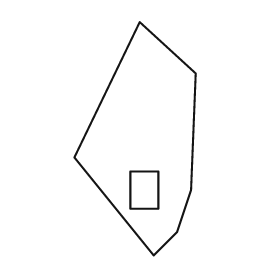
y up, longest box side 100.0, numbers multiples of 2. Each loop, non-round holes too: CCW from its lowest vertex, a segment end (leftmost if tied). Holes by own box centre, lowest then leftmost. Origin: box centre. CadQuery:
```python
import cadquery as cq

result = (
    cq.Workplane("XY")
    .moveTo(8.0, -50.0)
    .lineTo(18.0, -40.0)
    .lineTo(24.0, -22.0)
    .lineTo(26.0, 28.0)
    .lineTo(2.0, 50.0)
    .lineTo(-26.0, -8.0)
    .close()
    .moveTo(-2.0, -30.0)
    .lineTo(10.0, -30.0)
    .lineTo(10.0, -14.0)
    .lineTo(-2.0, -14.0)
    .close()
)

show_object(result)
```